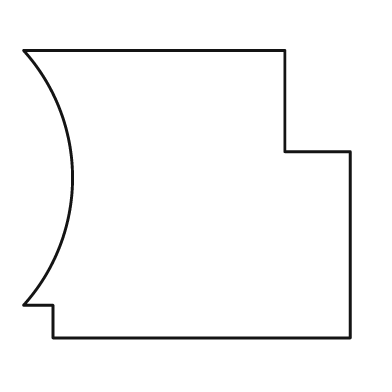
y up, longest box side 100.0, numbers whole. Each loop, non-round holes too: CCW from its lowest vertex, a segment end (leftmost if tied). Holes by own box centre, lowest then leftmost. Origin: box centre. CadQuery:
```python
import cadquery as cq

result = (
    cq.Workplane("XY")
    .moveTo(-41.0, -44.0)
    .lineTo(50.0, -44.0)
    .lineTo(50.0, 13.0)
    .lineTo(30.0, 13.0)
    .lineTo(30.0, 44.0)
    .lineTo(-50.0, 44.0)
    .threePointArc((-35.0, 5.0), (-50.0, -34.0))
    .lineTo(-41.0, -34.0)
    .close()
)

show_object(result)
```